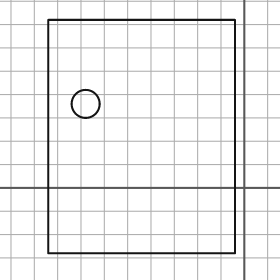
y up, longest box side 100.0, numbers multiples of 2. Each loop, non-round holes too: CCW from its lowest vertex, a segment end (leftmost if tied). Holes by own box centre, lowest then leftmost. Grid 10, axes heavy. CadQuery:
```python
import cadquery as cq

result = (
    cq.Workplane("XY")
    .moveTo(-84.0, -28.0)
    .lineTo(-4.0, -28.0)
    .lineTo(-4.0, 72.0)
    .lineTo(-84.0, 72.0)
    .close()
    .moveTo(-68.0, 36.0)
    .circle(6.0)
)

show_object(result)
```